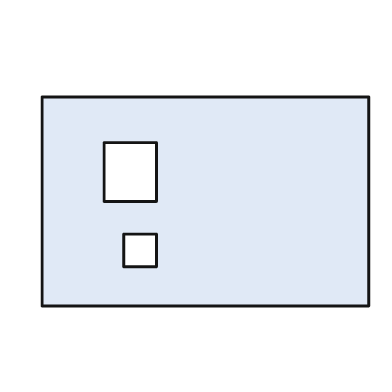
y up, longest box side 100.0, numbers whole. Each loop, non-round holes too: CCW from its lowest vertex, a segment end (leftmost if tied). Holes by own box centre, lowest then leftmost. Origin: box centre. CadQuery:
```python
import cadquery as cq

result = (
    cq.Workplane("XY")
    .moveTo(-50.0, -32.0)
    .lineTo(50.0, -32.0)
    .lineTo(50.0, 32.0)
    .lineTo(-50.0, 32.0)
    .close()
    .moveTo(-25.0, -20.0)
    .lineTo(-15.0, -20.0)
    .lineTo(-15.0, -10.0)
    .lineTo(-25.0, -10.0)
    .close()
    .moveTo(-31.0, 0.0)
    .lineTo(-15.0, 0.0)
    .lineTo(-15.0, 18.0)
    .lineTo(-31.0, 18.0)
    .close()
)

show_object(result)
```